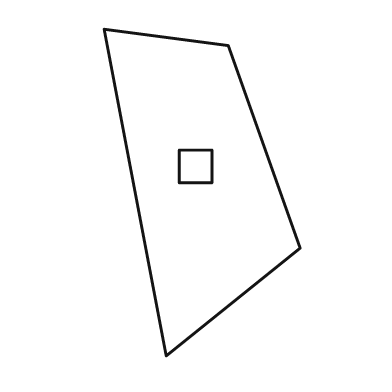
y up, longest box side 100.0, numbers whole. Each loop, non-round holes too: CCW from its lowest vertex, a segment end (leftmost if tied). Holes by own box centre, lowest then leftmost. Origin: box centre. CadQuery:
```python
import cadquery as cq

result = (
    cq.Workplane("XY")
    .moveTo(-11.0, -50.0)
    .lineTo(30.0, -17.0)
    .lineTo(8.0, 45.0)
    .lineTo(-30.0, 50.0)
    .close()
    .moveTo(-7.0, 3.0)
    .lineTo(3.0, 3.0)
    .lineTo(3.0, 13.0)
    .lineTo(-7.0, 13.0)
    .close()
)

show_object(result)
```